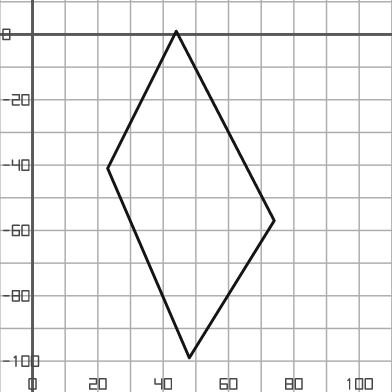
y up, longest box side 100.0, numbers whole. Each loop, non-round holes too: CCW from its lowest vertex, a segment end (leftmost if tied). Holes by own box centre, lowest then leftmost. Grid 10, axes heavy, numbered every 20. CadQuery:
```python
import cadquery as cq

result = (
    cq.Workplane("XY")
    .moveTo(48.0, -99.0)
    .lineTo(74.0, -57.0)
    .lineTo(44.0, 1.0)
    .lineTo(23.0, -41.0)
    .close()
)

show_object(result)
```